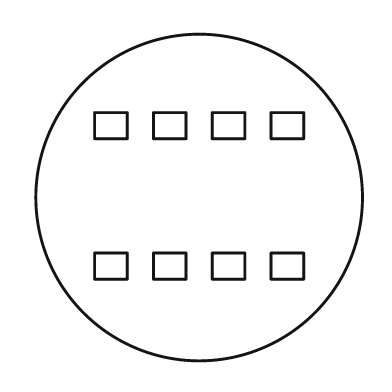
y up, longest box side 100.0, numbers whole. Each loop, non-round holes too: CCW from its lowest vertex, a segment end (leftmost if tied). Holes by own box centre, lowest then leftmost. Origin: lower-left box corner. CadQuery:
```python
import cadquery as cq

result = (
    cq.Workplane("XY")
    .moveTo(50.0, 50.0)
    .circle(50.0)
    .moveTo(18.0, 25.0)
    .lineTo(28.0, 25.0)
    .lineTo(28.0, 33.0)
    .lineTo(18.0, 33.0)
    .close()
    .moveTo(36.0, 25.0)
    .lineTo(46.0, 25.0)
    .lineTo(46.0, 33.0)
    .lineTo(36.0, 33.0)
    .close()
    .moveTo(54.0, 25.0)
    .lineTo(64.0, 25.0)
    .lineTo(64.0, 33.0)
    .lineTo(54.0, 33.0)
    .close()
    .moveTo(72.0, 25.0)
    .lineTo(82.0, 25.0)
    .lineTo(82.0, 33.0)
    .lineTo(72.0, 33.0)
    .close()
    .moveTo(18.0, 68.0)
    .lineTo(28.0, 68.0)
    .lineTo(28.0, 76.0)
    .lineTo(18.0, 76.0)
    .close()
    .moveTo(36.0, 68.0)
    .lineTo(46.0, 68.0)
    .lineTo(46.0, 76.0)
    .lineTo(36.0, 76.0)
    .close()
    .moveTo(54.0, 68.0)
    .lineTo(64.0, 68.0)
    .lineTo(64.0, 76.0)
    .lineTo(54.0, 76.0)
    .close()
    .moveTo(72.0, 68.0)
    .lineTo(82.0, 68.0)
    .lineTo(82.0, 76.0)
    .lineTo(72.0, 76.0)
    .close()
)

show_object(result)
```